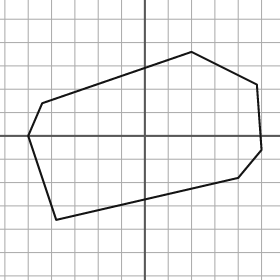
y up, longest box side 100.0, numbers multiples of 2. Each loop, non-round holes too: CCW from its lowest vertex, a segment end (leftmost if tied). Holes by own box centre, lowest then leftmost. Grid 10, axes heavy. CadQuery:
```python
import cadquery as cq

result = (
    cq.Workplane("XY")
    .moveTo(-38.0, -36.0)
    .lineTo(40.0, -18.0)
    .lineTo(50.0, -6.0)
    .lineTo(48.0, 22.0)
    .lineTo(20.0, 36.0)
    .lineTo(-44.0, 14.0)
    .lineTo(-50.0, 0.0)
    .close()
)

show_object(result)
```